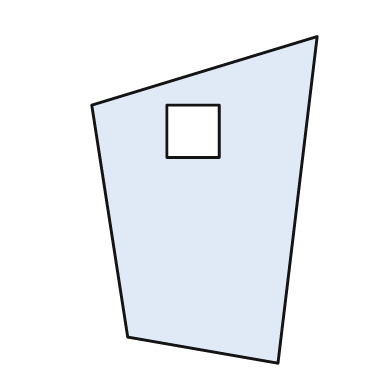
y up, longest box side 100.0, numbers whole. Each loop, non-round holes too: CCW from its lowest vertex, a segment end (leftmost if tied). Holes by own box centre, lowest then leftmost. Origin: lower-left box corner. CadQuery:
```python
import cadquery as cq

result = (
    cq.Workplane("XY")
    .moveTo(57.0, 0.0)
    .lineTo(69.0, 100.0)
    .lineTo(0.0, 79.0)
    .lineTo(11.0, 8.0)
    .close()
    .moveTo(23.0, 63.0)
    .lineTo(39.0, 63.0)
    .lineTo(39.0, 79.0)
    .lineTo(23.0, 79.0)
    .close()
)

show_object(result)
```